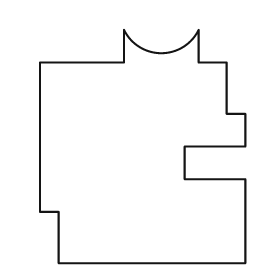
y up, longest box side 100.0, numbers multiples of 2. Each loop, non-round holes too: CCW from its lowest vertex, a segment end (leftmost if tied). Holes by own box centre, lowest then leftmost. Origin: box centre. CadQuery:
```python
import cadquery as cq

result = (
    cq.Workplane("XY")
    .moveTo(-36.0, -50.0)
    .lineTo(44.0, -50.0)
    .lineTo(44.0, -14.0)
    .lineTo(18.0, -14.0)
    .lineTo(18.0, 0.0)
    .lineTo(44.0, 0.0)
    .lineTo(44.0, 14.0)
    .lineTo(36.0, 14.0)
    .lineTo(36.0, 36.0)
    .lineTo(24.0, 36.0)
    .lineTo(24.0, 50.0)
    .threePointArc((8.0, 40.0), (-8.0, 50.0))
    .lineTo(-8.0, 36.0)
    .lineTo(-44.0, 36.0)
    .lineTo(-44.0, -28.0)
    .lineTo(-36.0, -28.0)
    .close()
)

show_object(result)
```